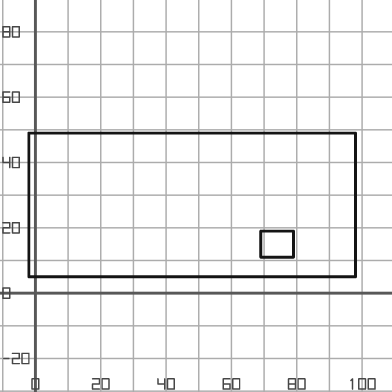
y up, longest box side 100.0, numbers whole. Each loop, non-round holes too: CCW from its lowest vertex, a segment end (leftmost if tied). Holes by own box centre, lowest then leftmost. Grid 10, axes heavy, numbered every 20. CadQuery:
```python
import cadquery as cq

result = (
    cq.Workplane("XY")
    .moveTo(-2.0, 5.0)
    .lineTo(98.0, 5.0)
    .lineTo(98.0, 49.0)
    .lineTo(-2.0, 49.0)
    .close()
    .moveTo(69.0, 11.0)
    .lineTo(79.0, 11.0)
    .lineTo(79.0, 19.0)
    .lineTo(69.0, 19.0)
    .close()
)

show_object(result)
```